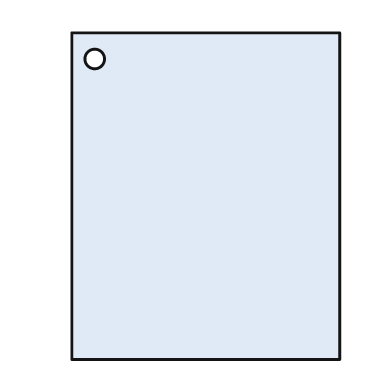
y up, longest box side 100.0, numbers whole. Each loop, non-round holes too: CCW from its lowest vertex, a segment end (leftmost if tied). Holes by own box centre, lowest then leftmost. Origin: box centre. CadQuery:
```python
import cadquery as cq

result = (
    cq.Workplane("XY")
    .moveTo(-41.0, -50.0)
    .lineTo(41.0, -50.0)
    .lineTo(41.0, 50.0)
    .lineTo(-41.0, 50.0)
    .close()
    .moveTo(-34.0, 42.0)
    .circle(3.0)
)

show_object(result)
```